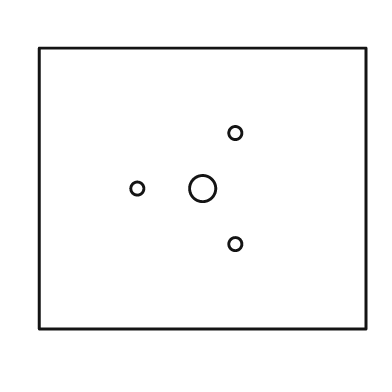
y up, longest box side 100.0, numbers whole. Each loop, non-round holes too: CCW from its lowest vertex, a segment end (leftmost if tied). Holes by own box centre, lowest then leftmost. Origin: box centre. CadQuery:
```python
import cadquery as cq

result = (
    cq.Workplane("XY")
    .moveTo(-50.0, -43.0)
    .lineTo(50.0, -43.0)
    .lineTo(50.0, 43.0)
    .lineTo(-50.0, 43.0)
    .close()
    .moveTo(10.0, -17.0)
    .circle(2.0)
    .moveTo(-20.0, 0.0)
    .circle(2.0)
    .moveTo(0.0, 0.0)
    .circle(4.0)
    .moveTo(10.0, 17.0)
    .circle(2.0)
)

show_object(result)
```